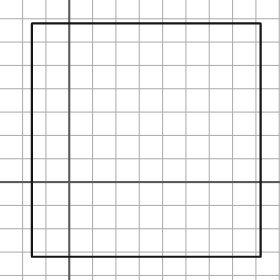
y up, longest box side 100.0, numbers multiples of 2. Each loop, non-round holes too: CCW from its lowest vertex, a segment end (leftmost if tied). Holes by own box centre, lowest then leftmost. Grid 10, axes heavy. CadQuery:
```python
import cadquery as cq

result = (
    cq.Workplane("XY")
    .moveTo(-16.0, -32.0)
    .lineTo(82.0, -32.0)
    .lineTo(82.0, 68.0)
    .lineTo(-16.0, 68.0)
    .close()
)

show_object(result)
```